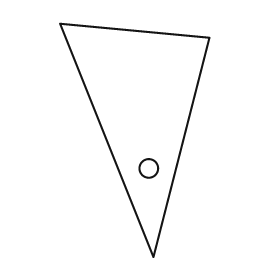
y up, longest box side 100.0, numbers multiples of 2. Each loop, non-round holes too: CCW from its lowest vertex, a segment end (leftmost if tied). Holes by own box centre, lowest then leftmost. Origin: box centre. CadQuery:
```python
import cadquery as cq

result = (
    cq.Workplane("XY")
    .moveTo(8.0, -50.0)
    .lineTo(32.0, 44.0)
    .lineTo(-32.0, 50.0)
    .close()
    .moveTo(6.0, -12.0)
    .circle(4.0)
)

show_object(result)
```